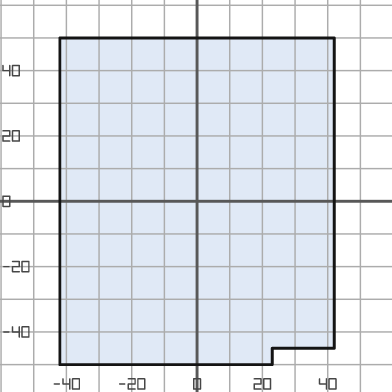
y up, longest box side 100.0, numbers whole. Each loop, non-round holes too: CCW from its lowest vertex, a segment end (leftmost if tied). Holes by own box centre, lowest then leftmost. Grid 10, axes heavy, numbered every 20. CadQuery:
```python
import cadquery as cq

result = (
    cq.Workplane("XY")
    .moveTo(-42.0, -50.0)
    .lineTo(23.0, -50.0)
    .lineTo(23.0, -45.0)
    .lineTo(42.0, -45.0)
    .lineTo(42.0, 50.0)
    .lineTo(-42.0, 50.0)
    .close()
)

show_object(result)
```